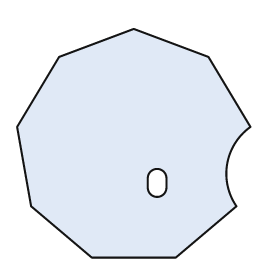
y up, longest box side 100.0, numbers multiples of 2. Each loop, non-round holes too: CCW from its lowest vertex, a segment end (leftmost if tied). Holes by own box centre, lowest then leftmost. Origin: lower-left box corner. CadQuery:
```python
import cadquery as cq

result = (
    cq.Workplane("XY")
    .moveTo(32.0, 0.0)
    .lineTo(68.0, 0.0)
    .lineTo(94.0, 22.0)
    .threePointArc((90.0, 40.0), (100.0, 56.0))
    .lineTo(82.0, 86.0)
    .lineTo(50.0, 98.0)
    .lineTo(18.0, 86.0)
    .lineTo(0.0, 56.0)
    .lineTo(6.0, 22.0)
    .close()
    .moveTo(56.0, 30.0)
    .threePointArc((60.0, 26.0), (64.0, 30.0))
    .lineTo(64.0, 34.0)
    .threePointArc((60.0, 38.0), (56.0, 34.0))
    .close()
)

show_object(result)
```